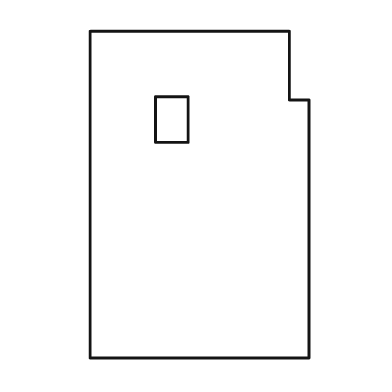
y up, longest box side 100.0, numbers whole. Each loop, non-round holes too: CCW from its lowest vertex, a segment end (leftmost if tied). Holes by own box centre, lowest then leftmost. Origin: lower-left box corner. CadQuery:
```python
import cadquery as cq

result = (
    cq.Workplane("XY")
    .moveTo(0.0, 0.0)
    .lineTo(67.0, 0.0)
    .lineTo(67.0, 79.0)
    .lineTo(61.0, 79.0)
    .lineTo(61.0, 100.0)
    .lineTo(0.0, 100.0)
    .close()
    .moveTo(20.0, 66.0)
    .lineTo(30.0, 66.0)
    .lineTo(30.0, 80.0)
    .lineTo(20.0, 80.0)
    .close()
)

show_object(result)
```